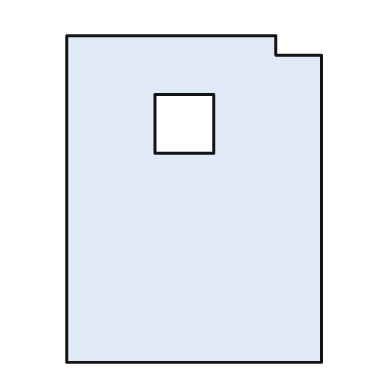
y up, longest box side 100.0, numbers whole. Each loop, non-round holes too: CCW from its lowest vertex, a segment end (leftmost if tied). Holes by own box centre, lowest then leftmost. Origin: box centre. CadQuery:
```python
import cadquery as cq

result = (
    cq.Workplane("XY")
    .moveTo(-39.0, -50.0)
    .lineTo(39.0, -50.0)
    .lineTo(39.0, 44.0)
    .lineTo(25.0, 44.0)
    .lineTo(25.0, 50.0)
    .lineTo(-39.0, 50.0)
    .close()
    .moveTo(-12.0, 14.0)
    .lineTo(6.0, 14.0)
    .lineTo(6.0, 32.0)
    .lineTo(-12.0, 32.0)
    .close()
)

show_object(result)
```